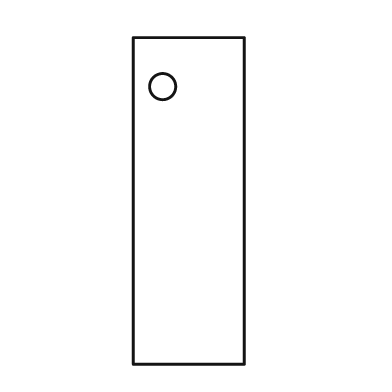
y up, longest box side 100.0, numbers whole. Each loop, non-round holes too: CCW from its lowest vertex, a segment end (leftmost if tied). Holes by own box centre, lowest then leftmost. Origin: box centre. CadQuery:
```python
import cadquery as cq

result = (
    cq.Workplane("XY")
    .moveTo(-17.0, -50.0)
    .lineTo(17.0, -50.0)
    .lineTo(17.0, 50.0)
    .lineTo(-17.0, 50.0)
    .close()
    .moveTo(-8.0, 35.0)
    .circle(4.0)
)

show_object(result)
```